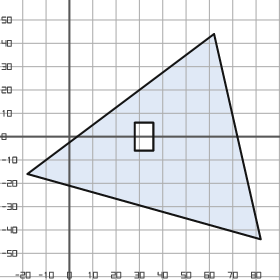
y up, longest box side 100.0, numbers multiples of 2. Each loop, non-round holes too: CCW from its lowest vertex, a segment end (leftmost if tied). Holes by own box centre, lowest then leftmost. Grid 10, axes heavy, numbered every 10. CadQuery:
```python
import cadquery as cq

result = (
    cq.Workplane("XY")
    .moveTo(82.0, -44.0)
    .lineTo(62.0, 44.0)
    .lineTo(-18.0, -16.0)
    .close()
    .moveTo(28.0, -6.0)
    .lineTo(36.0, -6.0)
    .lineTo(36.0, 6.0)
    .lineTo(28.0, 6.0)
    .close()
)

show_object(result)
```